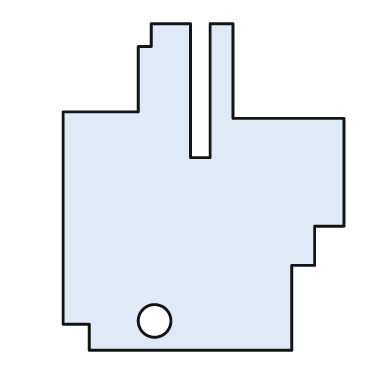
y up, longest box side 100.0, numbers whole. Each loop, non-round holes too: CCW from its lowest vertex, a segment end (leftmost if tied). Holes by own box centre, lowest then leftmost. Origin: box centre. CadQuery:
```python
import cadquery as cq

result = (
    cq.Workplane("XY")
    .moveTo(-35.0, -50.0)
    .lineTo(27.0, -50.0)
    .lineTo(27.0, -24.0)
    .lineTo(34.0, -24.0)
    .lineTo(34.0, -12.0)
    .lineTo(43.0, -12.0)
    .lineTo(43.0, 21.0)
    .lineTo(9.0, 21.0)
    .lineTo(9.0, 50.0)
    .lineTo(2.0, 50.0)
    .lineTo(2.0, 9.0)
    .lineTo(-4.0, 9.0)
    .lineTo(-4.0, 50.0)
    .lineTo(-16.0, 50.0)
    .lineTo(-16.0, 43.0)
    .lineTo(-20.0, 43.0)
    .lineTo(-20.0, 23.0)
    .lineTo(-43.0, 23.0)
    .lineTo(-43.0, -42.0)
    .lineTo(-35.0, -42.0)
    .close()
    .moveTo(-15.0, -41.0)
    .circle(5.0)
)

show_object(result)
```